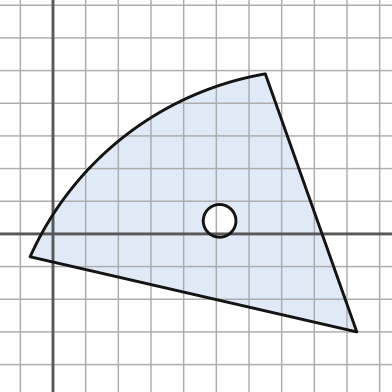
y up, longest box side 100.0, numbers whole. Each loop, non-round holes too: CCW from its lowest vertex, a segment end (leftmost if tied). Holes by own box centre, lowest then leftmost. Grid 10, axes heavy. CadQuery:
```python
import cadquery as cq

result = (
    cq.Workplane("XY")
    .moveTo(93.0, -30.0)
    .lineTo(65.0, 49.0)
    .threePointArc((22.0, 30.0), (-7.0, -7.0))
    .close()
    .moveTo(51.0, 4.0)
    .circle(5.0)
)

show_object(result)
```